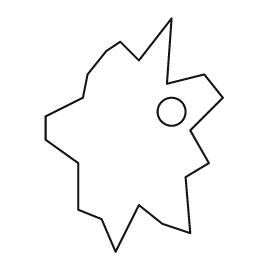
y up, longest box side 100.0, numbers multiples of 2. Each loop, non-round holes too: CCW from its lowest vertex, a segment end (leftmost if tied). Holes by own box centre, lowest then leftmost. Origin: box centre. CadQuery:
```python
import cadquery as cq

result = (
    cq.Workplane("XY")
    .moveTo(-8.0, -50.0)
    .lineTo(2.0, -30.0)
    .lineTo(12.0, -38.0)
    .lineTo(24.0, -42.0)
    .lineTo(22.0, -18.0)
    .lineTo(32.0, -12.0)
    .lineTo(24.0, 2.0)
    .lineTo(38.0, 16.0)
    .lineTo(30.0, 26.0)
    .lineTo(14.0, 22.0)
    .lineTo(16.0, 50.0)
    .lineTo(2.0, 32.0)
    .lineTo(-6.0, 40.0)
    .lineTo(-12.0, 36.0)
    .lineTo(-20.0, 26.0)
    .lineTo(-22.0, 16.0)
    .lineTo(-38.0, 8.0)
    .lineTo(-38.0, -2.0)
    .lineTo(-24.0, -12.0)
    .lineTo(-24.0, -32.0)
    .lineTo(-14.0, -36.0)
    .close()
    .moveTo(16.0, 10.0)
    .circle(6.0)
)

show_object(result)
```